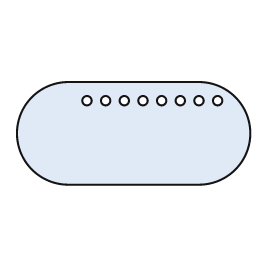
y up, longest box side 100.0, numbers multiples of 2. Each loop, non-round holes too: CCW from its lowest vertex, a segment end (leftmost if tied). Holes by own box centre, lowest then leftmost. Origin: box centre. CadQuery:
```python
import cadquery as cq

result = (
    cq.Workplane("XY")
    .moveTo(-28.0, -22.0)
    .lineTo(28.0, -22.0)
    .threePointArc((50.0, 0.0), (28.0, 22.0))
    .lineTo(-28.0, 22.0)
    .threePointArc((-50.0, 0.0), (-28.0, -22.0))
    .close()
    .moveTo(-20.0, 14.0)
    .circle(2.0)
    .moveTo(-12.0, 14.0)
    .circle(2.0)
    .moveTo(-4.0, 14.0)
    .circle(2.0)
    .moveTo(4.0, 14.0)
    .circle(2.0)
    .moveTo(12.0, 14.0)
    .circle(2.0)
    .moveTo(20.0, 14.0)
    .circle(2.0)
    .moveTo(28.0, 14.0)
    .circle(2.0)
    .moveTo(36.0, 14.0)
    .circle(2.0)
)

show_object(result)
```